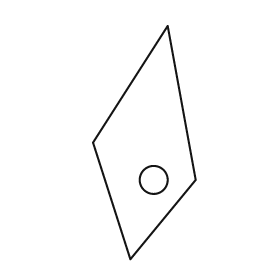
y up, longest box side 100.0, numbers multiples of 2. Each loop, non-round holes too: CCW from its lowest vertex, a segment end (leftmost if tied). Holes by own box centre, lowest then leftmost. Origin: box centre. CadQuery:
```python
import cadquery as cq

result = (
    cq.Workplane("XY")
    .moveTo(-6.0, -50.0)
    .lineTo(22.0, -16.0)
    .lineTo(10.0, 50.0)
    .lineTo(-22.0, 0.0)
    .close()
    .moveTo(4.0, -16.0)
    .circle(6.0)
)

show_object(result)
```